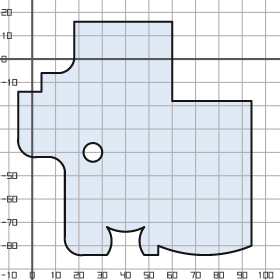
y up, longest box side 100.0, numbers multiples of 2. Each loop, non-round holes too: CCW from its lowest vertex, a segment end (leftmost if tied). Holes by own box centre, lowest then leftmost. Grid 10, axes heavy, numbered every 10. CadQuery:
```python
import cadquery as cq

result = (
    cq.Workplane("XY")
    .moveTo(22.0, -84.0)
    .lineTo(32.0, -84.0)
    .threePointArc((34.0, -78.0), (32.0, -72.0))
    .threePointArc((40.0, -74.0), (48.0, -72.0))
    .threePointArc((46.0, -78.0), (48.0, -84.0))
    .lineTo(54.0, -84.0)
    .lineTo(54.0, -80.0)
    .threePointArc((74.0, -84.0), (94.0, -80.0))
    .lineTo(94.0, -18.0)
    .lineTo(60.0, -18.0)
    .lineTo(60.0, 16.0)
    .lineTo(18.0, 16.0)
    .lineTo(18.0, 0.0)
    .threePointArc((16.0, -4.0), (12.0, -6.0))
    .lineTo(4.0, -6.0)
    .lineTo(4.0, -14.0)
    .lineTo(-6.0, -14.0)
    .lineTo(-6.0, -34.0)
    .threePointArc((-4.0, -40.0), (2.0, -42.0))
    .lineTo(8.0, -42.0)
    .threePointArc((12.0, -44.0), (14.0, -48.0))
    .lineTo(14.0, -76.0)
    .threePointArc((16.0, -82.0), (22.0, -84.0))
    .close()
    .moveTo(26.0, -40.0)
    .circle(4.0)
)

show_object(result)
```